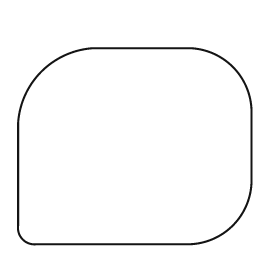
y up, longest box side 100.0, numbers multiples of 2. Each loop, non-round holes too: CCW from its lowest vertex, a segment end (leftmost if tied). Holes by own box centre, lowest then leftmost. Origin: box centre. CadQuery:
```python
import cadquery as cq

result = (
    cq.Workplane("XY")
    .moveTo(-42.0, -42.0)
    .lineTo(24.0, -42.0)
    .threePointArc((42.0, -34.0), (50.0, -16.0))
    .lineTo(50.0, 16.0)
    .threePointArc((42.0, 34.0), (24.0, 42.0))
    .lineTo(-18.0, 42.0)
    .threePointArc((-40.0, 32.0), (-50.0, 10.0))
    .lineTo(-50.0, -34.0)
    .threePointArc((-48.0, -40.0), (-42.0, -42.0))
    .close()
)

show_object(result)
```